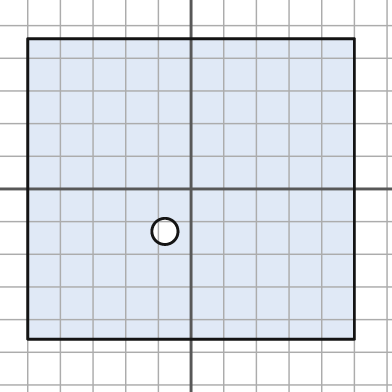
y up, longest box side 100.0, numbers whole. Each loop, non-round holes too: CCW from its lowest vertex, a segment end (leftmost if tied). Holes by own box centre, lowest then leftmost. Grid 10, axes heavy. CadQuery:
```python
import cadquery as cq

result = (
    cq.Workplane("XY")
    .moveTo(-50.0, -46.0)
    .lineTo(50.0, -46.0)
    .lineTo(50.0, 46.0)
    .lineTo(-50.0, 46.0)
    .close()
    .moveTo(-8.0, -13.0)
    .circle(4.0)
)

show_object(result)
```